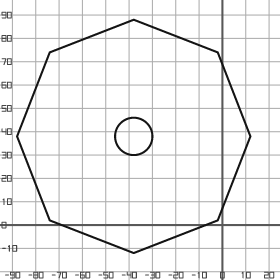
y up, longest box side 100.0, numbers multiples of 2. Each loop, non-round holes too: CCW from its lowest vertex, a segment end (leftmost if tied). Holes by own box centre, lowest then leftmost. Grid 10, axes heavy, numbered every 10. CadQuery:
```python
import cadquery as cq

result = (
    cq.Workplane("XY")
    .moveTo(-38.0, -12.0)
    .lineTo(-2.0, 2.0)
    .lineTo(12.0, 38.0)
    .lineTo(-2.0, 74.0)
    .lineTo(-38.0, 88.0)
    .lineTo(-74.0, 74.0)
    .lineTo(-88.0, 38.0)
    .lineTo(-74.0, 2.0)
    .close()
    .moveTo(-38.0, 38.0)
    .circle(8.0)
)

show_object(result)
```